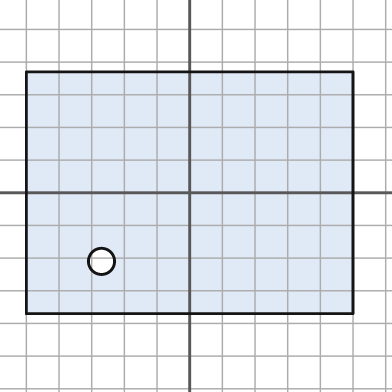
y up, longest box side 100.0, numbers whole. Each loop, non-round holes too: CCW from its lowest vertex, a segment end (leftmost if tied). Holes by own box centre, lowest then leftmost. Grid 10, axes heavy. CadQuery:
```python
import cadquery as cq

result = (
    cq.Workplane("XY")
    .moveTo(-50.0, -37.0)
    .lineTo(50.0, -37.0)
    .lineTo(50.0, 37.0)
    .lineTo(-50.0, 37.0)
    .close()
    .moveTo(-27.0, -21.0)
    .circle(4.0)
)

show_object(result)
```